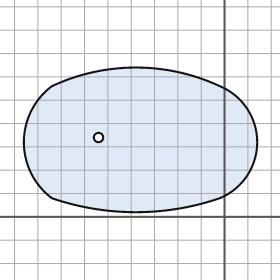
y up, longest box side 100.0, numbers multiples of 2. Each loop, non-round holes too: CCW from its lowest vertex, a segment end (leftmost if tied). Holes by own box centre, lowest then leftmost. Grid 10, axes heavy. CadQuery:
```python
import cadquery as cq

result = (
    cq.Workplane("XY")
    .moveTo(-74.0, 8.0)
    .threePointArc((-38.0, 2.0), (-2.0, 8.0))
    .threePointArc((14.0, 32.0), (-2.0, 56.0))
    .threePointArc((-38.0, 64.0), (-74.0, 56.0))
    .threePointArc((-86.0, 32.0), (-74.0, 8.0))
    .close()
    .moveTo(-54.0, 34.0)
    .circle(2.0)
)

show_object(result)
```